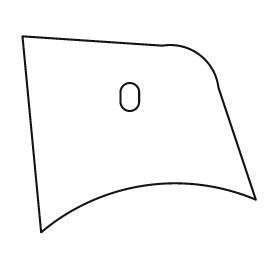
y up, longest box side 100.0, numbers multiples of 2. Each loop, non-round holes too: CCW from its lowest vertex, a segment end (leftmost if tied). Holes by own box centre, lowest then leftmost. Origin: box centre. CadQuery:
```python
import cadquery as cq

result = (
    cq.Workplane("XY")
    .moveTo(-42.0, -42.0)
    .threePointArc((2.0, -22.0), (50.0, -28.0))
    .lineTo(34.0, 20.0)
    .threePointArc((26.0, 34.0), (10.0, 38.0))
    .lineTo(-50.0, 42.0)
    .close()
    .moveTo(-8.0, 14.0)
    .threePointArc((-4.0, 10.0), (0.0, 14.0))
    .lineTo(0.0, 18.0)
    .threePointArc((-4.0, 22.0), (-8.0, 18.0))
    .close()
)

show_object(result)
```